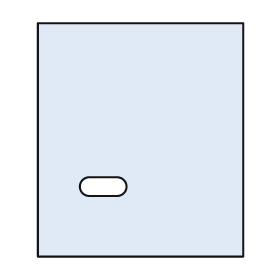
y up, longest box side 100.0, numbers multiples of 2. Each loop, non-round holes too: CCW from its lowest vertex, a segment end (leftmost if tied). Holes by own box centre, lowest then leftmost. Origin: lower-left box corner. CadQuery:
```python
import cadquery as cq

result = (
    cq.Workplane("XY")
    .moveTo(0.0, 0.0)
    .lineTo(88.0, 0.0)
    .lineTo(88.0, 100.0)
    .lineTo(0.0, 100.0)
    .close()
    .moveTo(22.0, 26.0)
    .lineTo(34.0, 26.0)
    .threePointArc((38.0, 30.0), (34.0, 34.0))
    .lineTo(22.0, 34.0)
    .threePointArc((18.0, 30.0), (22.0, 26.0))
    .close()
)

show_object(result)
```